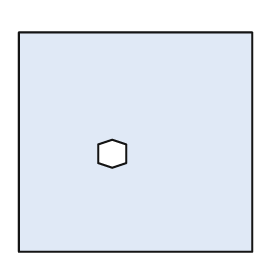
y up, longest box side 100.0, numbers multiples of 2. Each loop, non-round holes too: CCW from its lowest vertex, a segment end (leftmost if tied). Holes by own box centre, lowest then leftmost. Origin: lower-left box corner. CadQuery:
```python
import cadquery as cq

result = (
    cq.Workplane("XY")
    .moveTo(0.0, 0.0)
    .lineTo(100.0, 0.0)
    .lineTo(100.0, 94.0)
    .lineTo(0.0, 94.0)
    .close()
    .moveTo(40.0, 36.0)
    .lineTo(46.0, 38.0)
    .lineTo(46.0, 46.0)
    .lineTo(40.0, 48.0)
    .lineTo(34.0, 46.0)
    .lineTo(34.0, 38.0)
    .close()
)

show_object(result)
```